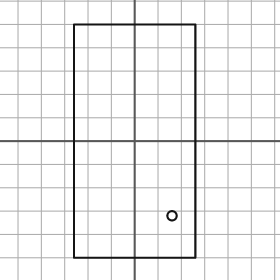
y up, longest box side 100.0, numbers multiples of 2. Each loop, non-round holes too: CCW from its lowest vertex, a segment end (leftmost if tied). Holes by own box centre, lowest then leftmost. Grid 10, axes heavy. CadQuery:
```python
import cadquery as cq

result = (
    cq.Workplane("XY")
    .moveTo(-26.0, -50.0)
    .lineTo(26.0, -50.0)
    .lineTo(26.0, 50.0)
    .lineTo(-26.0, 50.0)
    .close()
    .moveTo(16.0, -32.0)
    .circle(2.0)
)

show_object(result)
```